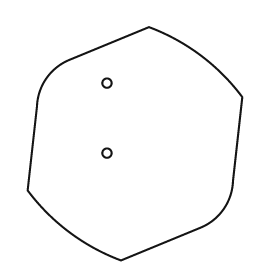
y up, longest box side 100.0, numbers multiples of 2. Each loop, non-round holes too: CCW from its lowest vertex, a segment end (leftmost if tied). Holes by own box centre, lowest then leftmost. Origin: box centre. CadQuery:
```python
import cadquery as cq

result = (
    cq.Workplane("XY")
    .moveTo(-6.0, -50.0)
    .lineTo(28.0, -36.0)
    .threePointArc((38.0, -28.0), (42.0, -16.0))
    .lineTo(46.0, 20.0)
    .threePointArc((28.0, 38.0), (6.0, 50.0))
    .lineTo(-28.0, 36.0)
    .threePointArc((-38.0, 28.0), (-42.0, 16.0))
    .lineTo(-46.0, -20.0)
    .threePointArc((-28.0, -38.0), (-6.0, -50.0))
    .close()
    .moveTo(-12.0, -4.0)
    .circle(2.0)
    .moveTo(-12.0, 26.0)
    .circle(2.0)
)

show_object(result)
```